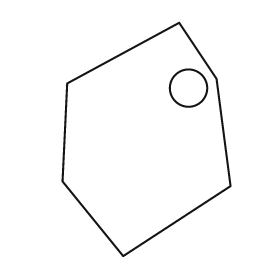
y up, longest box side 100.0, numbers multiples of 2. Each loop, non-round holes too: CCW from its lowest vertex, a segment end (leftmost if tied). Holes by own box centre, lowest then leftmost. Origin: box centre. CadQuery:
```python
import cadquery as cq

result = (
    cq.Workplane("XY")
    .moveTo(-10.0, -50.0)
    .lineTo(36.0, -20.0)
    .lineTo(30.0, 26.0)
    .lineTo(14.0, 50.0)
    .lineTo(-34.0, 24.0)
    .lineTo(-36.0, -18.0)
    .close()
    .moveTo(18.0, 22.0)
    .circle(8.0)
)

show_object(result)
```